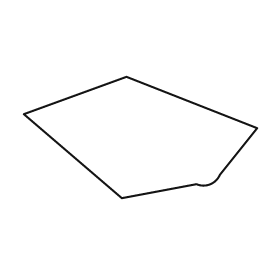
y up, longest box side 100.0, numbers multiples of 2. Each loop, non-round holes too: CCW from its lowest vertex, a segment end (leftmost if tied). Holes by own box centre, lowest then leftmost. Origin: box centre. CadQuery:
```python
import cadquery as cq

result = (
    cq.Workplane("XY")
    .moveTo(-8.0, -26.0)
    .lineTo(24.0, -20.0)
    .threePointArc((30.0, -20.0), (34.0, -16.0))
    .lineTo(50.0, 4.0)
    .lineTo(-6.0, 26.0)
    .lineTo(-50.0, 10.0)
    .close()
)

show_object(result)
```